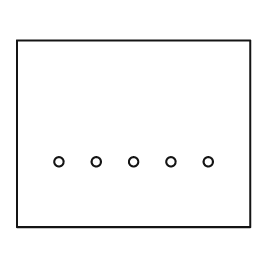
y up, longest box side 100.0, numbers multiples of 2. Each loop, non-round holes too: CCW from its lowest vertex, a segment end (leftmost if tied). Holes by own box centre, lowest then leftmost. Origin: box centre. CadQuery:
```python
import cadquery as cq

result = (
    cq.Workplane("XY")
    .moveTo(-50.0, -40.0)
    .lineTo(50.0, -40.0)
    .lineTo(50.0, 40.0)
    .lineTo(-50.0, 40.0)
    .close()
    .moveTo(-32.0, -12.0)
    .circle(2.0)
    .moveTo(-16.0, -12.0)
    .circle(2.0)
    .moveTo(0.0, -12.0)
    .circle(2.0)
    .moveTo(16.0, -12.0)
    .circle(2.0)
    .moveTo(32.0, -12.0)
    .circle(2.0)
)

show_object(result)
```